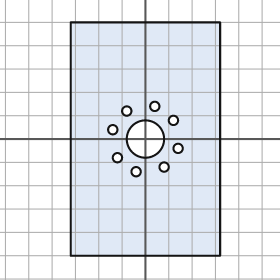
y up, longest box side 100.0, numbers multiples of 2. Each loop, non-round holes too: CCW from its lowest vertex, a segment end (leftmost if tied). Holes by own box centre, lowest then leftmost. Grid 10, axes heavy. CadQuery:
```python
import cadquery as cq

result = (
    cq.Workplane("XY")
    .moveTo(-32.0, -50.0)
    .lineTo(32.0, -50.0)
    .lineTo(32.0, 50.0)
    .lineTo(-32.0, 50.0)
    .close()
    .moveTo(-4.0, -14.0)
    .circle(2.0)
    .moveTo(8.0, -12.0)
    .circle(2.0)
    .moveTo(-12.0, -8.0)
    .circle(2.0)
    .moveTo(14.0, -4.0)
    .circle(2.0)
    .moveTo(0.0, 0.0)
    .circle(8.0)
    .moveTo(-14.0, 4.0)
    .circle(2.0)
    .moveTo(12.0, 8.0)
    .circle(2.0)
    .moveTo(-8.0, 12.0)
    .circle(2.0)
    .moveTo(4.0, 14.0)
    .circle(2.0)
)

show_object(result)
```